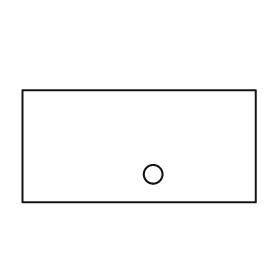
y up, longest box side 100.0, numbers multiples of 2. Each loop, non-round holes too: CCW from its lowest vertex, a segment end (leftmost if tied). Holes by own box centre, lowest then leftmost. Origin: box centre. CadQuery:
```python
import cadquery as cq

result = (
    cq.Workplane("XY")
    .moveTo(-50.0, -24.0)
    .lineTo(50.0, -24.0)
    .lineTo(50.0, 24.0)
    .lineTo(-50.0, 24.0)
    .close()
    .moveTo(6.0, -12.0)
    .circle(4.0)
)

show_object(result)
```